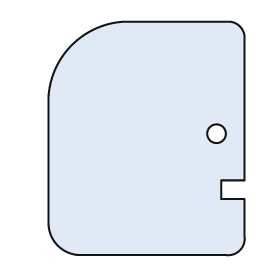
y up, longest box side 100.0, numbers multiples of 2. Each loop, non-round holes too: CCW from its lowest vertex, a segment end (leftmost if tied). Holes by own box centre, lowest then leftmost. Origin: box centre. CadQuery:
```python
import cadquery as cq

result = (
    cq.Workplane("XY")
    .moveTo(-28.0, -50.0)
    .lineTo(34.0, -50.0)
    .threePointArc((40.0, -48.0), (42.0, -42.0))
    .lineTo(42.0, -26.0)
    .lineTo(32.0, -26.0)
    .lineTo(32.0, -18.0)
    .lineTo(42.0, -18.0)
    .lineTo(42.0, 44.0)
    .threePointArc((40.0, 48.0), (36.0, 50.0))
    .lineTo(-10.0, 50.0)
    .threePointArc((-32.0, 40.0), (-42.0, 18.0))
    .lineTo(-42.0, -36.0)
    .threePointArc((-38.0, -46.0), (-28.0, -50.0))
    .close()
    .moveTo(30.0, 2.0)
    .circle(4.0)
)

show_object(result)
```